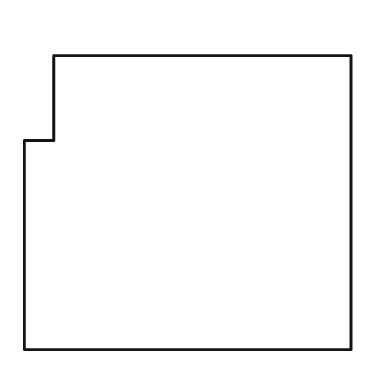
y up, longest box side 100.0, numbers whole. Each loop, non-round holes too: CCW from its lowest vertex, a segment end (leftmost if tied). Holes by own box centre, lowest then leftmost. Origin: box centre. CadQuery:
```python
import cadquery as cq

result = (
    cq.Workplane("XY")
    .moveTo(-50.0, -45.0)
    .lineTo(50.0, -45.0)
    .lineTo(50.0, 45.0)
    .lineTo(-41.0, 45.0)
    .lineTo(-41.0, 19.0)
    .lineTo(-50.0, 19.0)
    .close()
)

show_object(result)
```